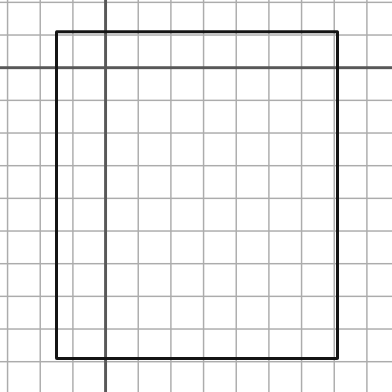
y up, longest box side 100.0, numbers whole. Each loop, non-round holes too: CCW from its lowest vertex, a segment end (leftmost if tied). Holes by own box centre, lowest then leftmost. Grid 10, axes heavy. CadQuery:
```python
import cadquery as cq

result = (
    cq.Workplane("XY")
    .moveTo(-15.0, -89.0)
    .lineTo(71.0, -89.0)
    .lineTo(71.0, 11.0)
    .lineTo(-15.0, 11.0)
    .close()
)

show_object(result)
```